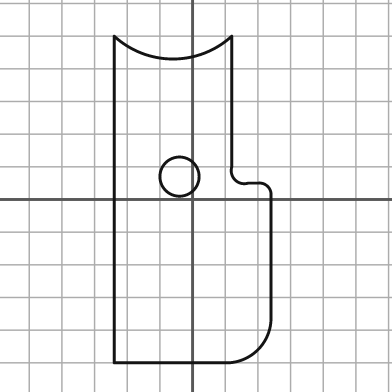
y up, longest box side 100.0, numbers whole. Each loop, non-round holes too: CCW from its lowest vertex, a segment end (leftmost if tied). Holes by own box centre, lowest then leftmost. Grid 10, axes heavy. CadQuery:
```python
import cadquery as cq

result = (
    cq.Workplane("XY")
    .moveTo(-24.0, -50.0)
    .lineTo(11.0, -50.0)
    .threePointArc((20.0, -46.0), (24.0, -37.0))
    .lineTo(24.0, 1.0)
    .threePointArc((23.0, 4.0), (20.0, 5.0))
    .lineTo(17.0, 5.0)
    .threePointArc((13.0, 6.0), (12.0, 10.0))
    .lineTo(12.0, 50.0)
    .threePointArc((-6.0, 43.0), (-24.0, 50.0))
    .close()
    .moveTo(-4.0, 7.0)
    .circle(6.0)
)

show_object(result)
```